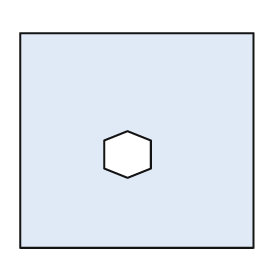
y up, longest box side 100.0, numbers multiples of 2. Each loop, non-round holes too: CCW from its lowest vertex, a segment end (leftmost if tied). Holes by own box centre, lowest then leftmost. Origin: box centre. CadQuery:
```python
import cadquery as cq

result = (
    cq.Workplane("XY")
    .moveTo(-50.0, -46.0)
    .lineTo(50.0, -46.0)
    .lineTo(50.0, 46.0)
    .lineTo(-50.0, 46.0)
    .close()
    .moveTo(-4.0, -16.0)
    .lineTo(6.0, -12.0)
    .lineTo(6.0, 0.0)
    .lineTo(-4.0, 4.0)
    .lineTo(-14.0, 0.0)
    .lineTo(-14.0, -12.0)
    .close()
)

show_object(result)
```